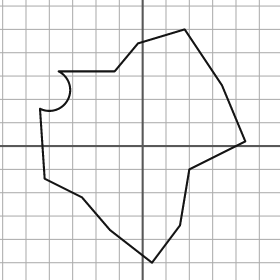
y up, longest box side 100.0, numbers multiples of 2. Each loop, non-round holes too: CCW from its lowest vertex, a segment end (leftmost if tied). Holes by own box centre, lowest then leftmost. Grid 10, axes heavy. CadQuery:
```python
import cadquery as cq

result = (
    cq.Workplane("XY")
    .moveTo(4.0, -50.0)
    .lineTo(16.0, -34.0)
    .lineTo(20.0, -10.0)
    .lineTo(44.0, 2.0)
    .lineTo(34.0, 26.0)
    .lineTo(18.0, 50.0)
    .lineTo(-2.0, 44.0)
    .lineTo(-12.0, 32.0)
    .lineTo(-36.0, 32.0)
    .threePointArc((-32.0, 20.0), (-44.0, 16.0))
    .lineTo(-42.0, -14.0)
    .lineTo(-26.0, -22.0)
    .lineTo(-14.0, -36.0)
    .close()
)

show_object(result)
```